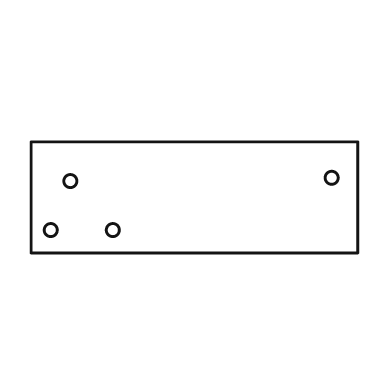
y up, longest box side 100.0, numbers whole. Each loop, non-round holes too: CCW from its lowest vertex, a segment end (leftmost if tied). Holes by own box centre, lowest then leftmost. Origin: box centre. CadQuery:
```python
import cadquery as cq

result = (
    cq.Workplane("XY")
    .moveTo(-50.0, -17.0)
    .lineTo(50.0, -17.0)
    .lineTo(50.0, 17.0)
    .lineTo(-50.0, 17.0)
    .close()
    .moveTo(-44.0, -10.0)
    .circle(2.0)
    .moveTo(-25.0, -10.0)
    .circle(2.0)
    .moveTo(-38.0, 5.0)
    .circle(2.0)
    .moveTo(42.0, 6.0)
    .circle(2.0)
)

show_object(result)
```